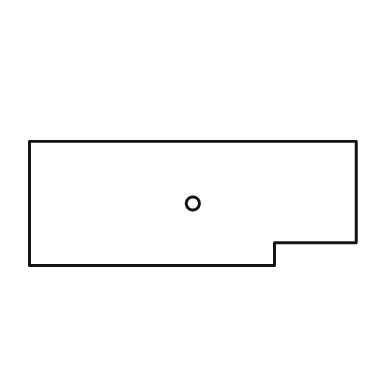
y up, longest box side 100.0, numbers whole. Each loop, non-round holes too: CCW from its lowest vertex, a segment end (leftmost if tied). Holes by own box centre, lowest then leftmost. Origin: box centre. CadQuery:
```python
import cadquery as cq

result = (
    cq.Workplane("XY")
    .moveTo(-50.0, -19.0)
    .lineTo(25.0, -19.0)
    .lineTo(25.0, -12.0)
    .lineTo(50.0, -12.0)
    .lineTo(50.0, 19.0)
    .lineTo(-50.0, 19.0)
    .close()
    .moveTo(0.0, 0.0)
    .circle(2.0)
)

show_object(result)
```